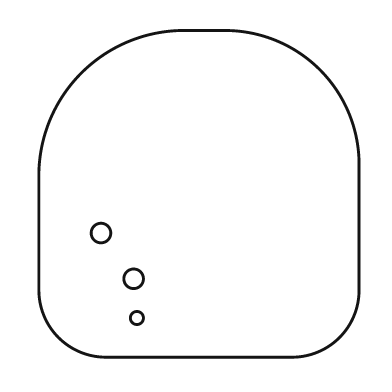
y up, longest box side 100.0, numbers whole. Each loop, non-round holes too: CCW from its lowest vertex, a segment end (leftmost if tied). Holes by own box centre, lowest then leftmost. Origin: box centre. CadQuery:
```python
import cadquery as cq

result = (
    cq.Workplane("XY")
    .moveTo(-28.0, -50.0)
    .lineTo(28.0, -50.0)
    .threePointArc((43.0, -44.0), (49.0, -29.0))
    .lineTo(49.0, 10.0)
    .threePointArc((37.0, 38.0), (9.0, 50.0))
    .lineTo(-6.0, 50.0)
    .threePointArc((-36.0, 37.0), (-49.0, 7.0))
    .lineTo(-49.0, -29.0)
    .threePointArc((-43.0, -44.0), (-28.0, -50.0))
    .close()
    .moveTo(-19.0, -38.0)
    .circle(2.0)
    .moveTo(-20.0, -26.0)
    .circle(3.0)
    .moveTo(-30.0, -12.0)
    .circle(3.0)
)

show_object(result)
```